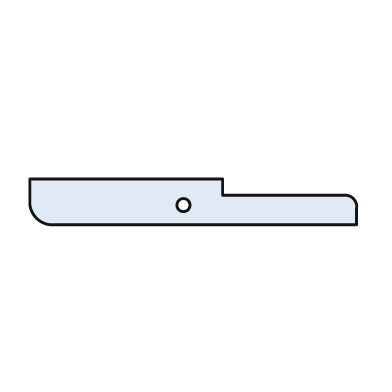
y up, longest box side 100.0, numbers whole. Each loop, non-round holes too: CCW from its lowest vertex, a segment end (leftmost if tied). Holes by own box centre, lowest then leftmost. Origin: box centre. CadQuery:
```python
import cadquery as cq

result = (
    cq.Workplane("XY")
    .moveTo(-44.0, -7.0)
    .lineTo(50.0, -7.0)
    .lineTo(50.0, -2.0)
    .threePointArc((49.0, 1.0), (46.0, 2.0))
    .lineTo(9.0, 2.0)
    .lineTo(9.0, 7.0)
    .lineTo(-50.0, 7.0)
    .lineTo(-50.0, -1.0)
    .threePointArc((-48.0, -5.0), (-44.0, -7.0))
    .close()
    .moveTo(-3.0, -1.0)
    .circle(2.0)
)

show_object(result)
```